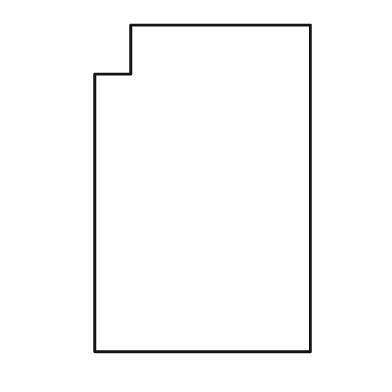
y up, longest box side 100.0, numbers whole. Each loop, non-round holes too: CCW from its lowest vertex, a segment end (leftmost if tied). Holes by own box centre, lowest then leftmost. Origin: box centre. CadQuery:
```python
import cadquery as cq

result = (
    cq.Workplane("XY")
    .moveTo(-33.0, -50.0)
    .lineTo(33.0, -50.0)
    .lineTo(33.0, 50.0)
    .lineTo(-22.0, 50.0)
    .lineTo(-22.0, 35.0)
    .lineTo(-33.0, 35.0)
    .close()
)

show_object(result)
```